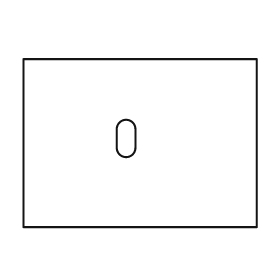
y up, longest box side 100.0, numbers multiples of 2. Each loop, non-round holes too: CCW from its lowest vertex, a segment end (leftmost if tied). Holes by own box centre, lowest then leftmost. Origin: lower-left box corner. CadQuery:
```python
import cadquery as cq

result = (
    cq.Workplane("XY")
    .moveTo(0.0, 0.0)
    .lineTo(100.0, 0.0)
    .lineTo(100.0, 72.0)
    .lineTo(0.0, 72.0)
    .close()
    .moveTo(40.0, 34.0)
    .threePointArc((44.0, 30.0), (48.0, 34.0))
    .lineTo(48.0, 42.0)
    .threePointArc((44.0, 46.0), (40.0, 42.0))
    .close()
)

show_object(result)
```